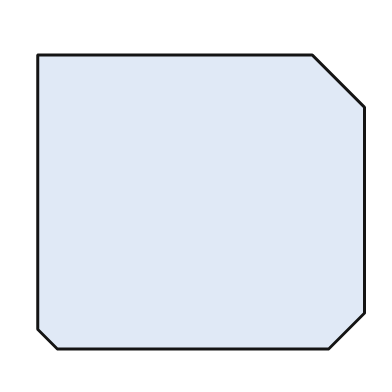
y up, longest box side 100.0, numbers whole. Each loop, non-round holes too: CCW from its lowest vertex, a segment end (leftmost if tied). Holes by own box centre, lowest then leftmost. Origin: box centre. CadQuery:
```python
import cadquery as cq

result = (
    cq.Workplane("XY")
    .moveTo(-44.0, -45.0)
    .lineTo(39.0, -45.0)
    .lineTo(50.0, -34.0)
    .lineTo(50.0, 29.0)
    .lineTo(34.0, 45.0)
    .lineTo(-50.0, 45.0)
    .lineTo(-50.0, -39.0)
    .close()
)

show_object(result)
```